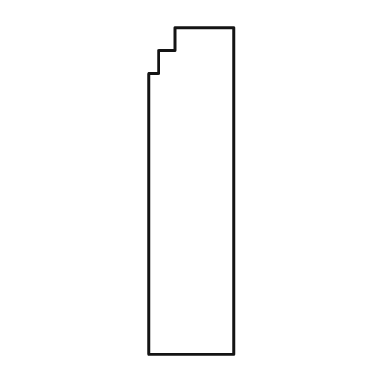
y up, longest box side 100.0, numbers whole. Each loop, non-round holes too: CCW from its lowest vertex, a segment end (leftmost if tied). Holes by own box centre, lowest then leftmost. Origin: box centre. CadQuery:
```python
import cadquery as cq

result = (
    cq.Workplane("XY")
    .moveTo(-13.0, -50.0)
    .lineTo(13.0, -50.0)
    .lineTo(13.0, 50.0)
    .lineTo(-5.0, 50.0)
    .lineTo(-5.0, 43.0)
    .lineTo(-10.0, 43.0)
    .lineTo(-10.0, 36.0)
    .lineTo(-13.0, 36.0)
    .close()
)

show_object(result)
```